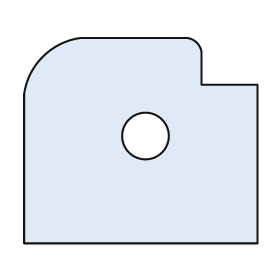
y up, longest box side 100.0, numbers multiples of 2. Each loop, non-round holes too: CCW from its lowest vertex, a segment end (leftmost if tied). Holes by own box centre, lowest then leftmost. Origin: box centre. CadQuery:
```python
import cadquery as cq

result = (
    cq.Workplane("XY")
    .moveTo(-50.0, -44.0)
    .lineTo(50.0, -44.0)
    .lineTo(50.0, 24.0)
    .lineTo(26.0, 24.0)
    .lineTo(26.0, 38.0)
    .threePointArc((24.0, 42.0), (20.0, 44.0))
    .lineTo(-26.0, 44.0)
    .threePointArc((-42.0, 36.0), (-50.0, 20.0))
    .close()
    .moveTo(2.0, 2.0)
    .circle(10.0)
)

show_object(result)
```